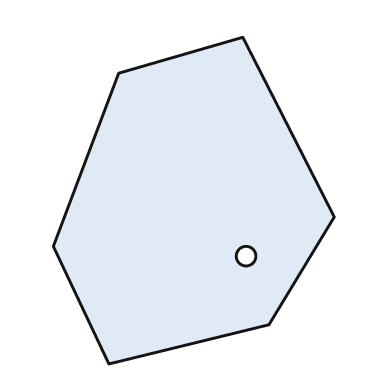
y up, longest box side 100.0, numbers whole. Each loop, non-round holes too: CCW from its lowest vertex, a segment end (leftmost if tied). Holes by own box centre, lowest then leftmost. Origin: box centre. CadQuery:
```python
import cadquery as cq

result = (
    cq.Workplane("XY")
    .moveTo(-26.0, -50.0)
    .lineTo(23.0, -38.0)
    .lineTo(43.0, -5.0)
    .lineTo(15.0, 50.0)
    .lineTo(-23.0, 39.0)
    .lineTo(-43.0, -14.0)
    .close()
    .moveTo(16.0, -17.0)
    .circle(3.0)
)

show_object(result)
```